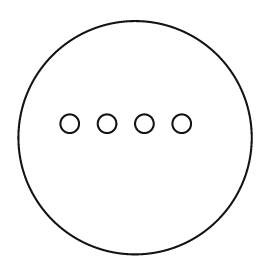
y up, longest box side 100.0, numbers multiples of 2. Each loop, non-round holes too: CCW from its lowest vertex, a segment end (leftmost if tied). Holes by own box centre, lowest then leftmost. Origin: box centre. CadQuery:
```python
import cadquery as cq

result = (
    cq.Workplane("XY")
    .moveTo(0.0, 0.0)
    .circle(50.0)
    .moveTo(-28.0, 6.0)
    .circle(4.0)
    .moveTo(-12.0, 6.0)
    .circle(4.0)
    .moveTo(4.0, 6.0)
    .circle(4.0)
    .moveTo(20.0, 6.0)
    .circle(4.0)
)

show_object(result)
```